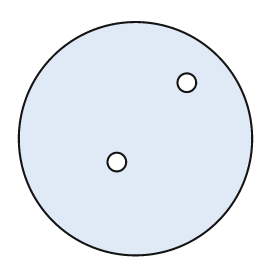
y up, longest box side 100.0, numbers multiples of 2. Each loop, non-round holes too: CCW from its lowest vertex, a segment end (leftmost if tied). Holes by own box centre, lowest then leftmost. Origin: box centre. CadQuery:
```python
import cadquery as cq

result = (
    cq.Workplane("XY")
    .moveTo(0.0, 0.0)
    .circle(50.0)
    .moveTo(-8.0, -10.0)
    .circle(4.0)
    .moveTo(22.0, 24.0)
    .circle(4.0)
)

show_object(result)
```